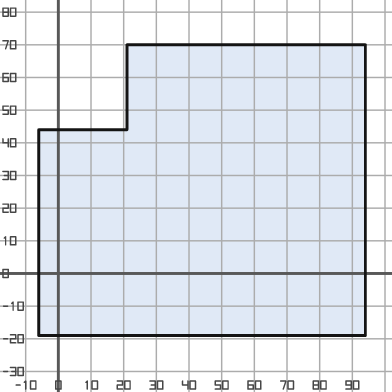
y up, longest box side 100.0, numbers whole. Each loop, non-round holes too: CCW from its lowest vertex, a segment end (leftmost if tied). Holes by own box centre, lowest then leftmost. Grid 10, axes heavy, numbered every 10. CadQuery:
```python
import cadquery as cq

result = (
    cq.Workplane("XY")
    .moveTo(-6.0, -19.0)
    .lineTo(94.0, -19.0)
    .lineTo(94.0, 70.0)
    .lineTo(21.0, 70.0)
    .lineTo(21.0, 44.0)
    .lineTo(-6.0, 44.0)
    .close()
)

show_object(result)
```